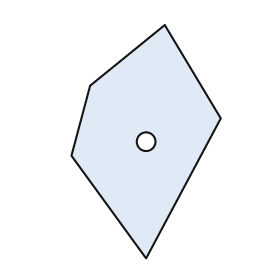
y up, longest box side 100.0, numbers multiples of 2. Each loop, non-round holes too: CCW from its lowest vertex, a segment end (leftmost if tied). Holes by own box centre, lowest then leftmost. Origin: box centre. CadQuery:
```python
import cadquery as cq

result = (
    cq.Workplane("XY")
    .moveTo(0.0, -50.0)
    .lineTo(32.0, 10.0)
    .lineTo(8.0, 50.0)
    .lineTo(-24.0, 24.0)
    .lineTo(-32.0, -6.0)
    .close()
    .moveTo(0.0, 0.0)
    .circle(4.0)
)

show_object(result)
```